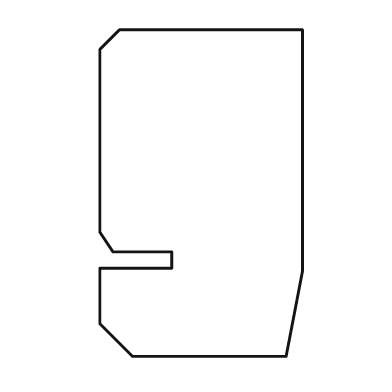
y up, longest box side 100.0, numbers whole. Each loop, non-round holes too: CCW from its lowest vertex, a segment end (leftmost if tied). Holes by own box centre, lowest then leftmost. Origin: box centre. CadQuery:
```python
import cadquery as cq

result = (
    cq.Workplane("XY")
    .moveTo(-21.0, -50.0)
    .lineTo(26.0, -50.0)
    .lineTo(31.0, -24.0)
    .lineTo(31.0, 50.0)
    .lineTo(-25.0, 50.0)
    .lineTo(-31.0, 44.0)
    .lineTo(-31.0, -12.0)
    .lineTo(-27.0, -18.0)
    .lineTo(-9.0, -18.0)
    .lineTo(-9.0, -23.0)
    .lineTo(-31.0, -23.0)
    .lineTo(-31.0, -40.0)
    .close()
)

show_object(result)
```